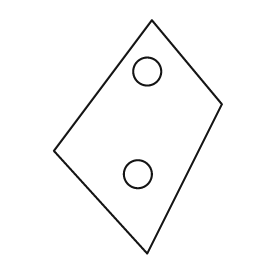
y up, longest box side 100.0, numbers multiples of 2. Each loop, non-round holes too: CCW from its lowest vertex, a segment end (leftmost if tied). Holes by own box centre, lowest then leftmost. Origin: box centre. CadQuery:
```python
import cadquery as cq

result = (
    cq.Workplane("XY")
    .moveTo(4.0, -50.0)
    .lineTo(36.0, 14.0)
    .lineTo(6.0, 50.0)
    .lineTo(-36.0, -6.0)
    .close()
    .moveTo(0.0, -16.0)
    .circle(6.0)
    .moveTo(4.0, 28.0)
    .circle(6.0)
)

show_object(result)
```